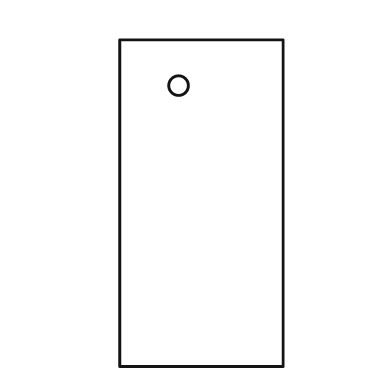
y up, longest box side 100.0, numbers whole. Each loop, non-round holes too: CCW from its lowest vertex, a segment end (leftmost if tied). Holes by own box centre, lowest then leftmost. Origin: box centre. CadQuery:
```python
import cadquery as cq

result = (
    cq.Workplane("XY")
    .moveTo(-25.0, -50.0)
    .lineTo(25.0, -50.0)
    .lineTo(25.0, 50.0)
    .lineTo(-25.0, 50.0)
    .close()
    .moveTo(-7.0, 36.0)
    .circle(3.0)
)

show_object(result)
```